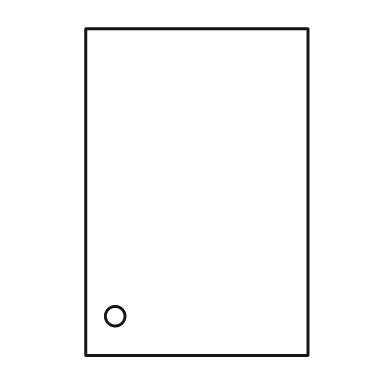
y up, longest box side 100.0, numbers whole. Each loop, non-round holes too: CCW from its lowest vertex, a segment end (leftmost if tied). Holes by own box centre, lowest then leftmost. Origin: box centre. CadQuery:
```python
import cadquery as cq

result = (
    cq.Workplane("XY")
    .moveTo(-34.0, -50.0)
    .lineTo(34.0, -50.0)
    .lineTo(34.0, 50.0)
    .lineTo(-34.0, 50.0)
    .close()
    .moveTo(-25.0, -38.0)
    .circle(3.0)
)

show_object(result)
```